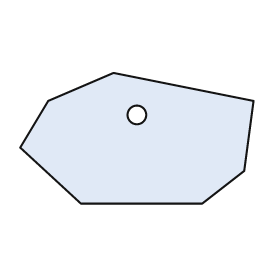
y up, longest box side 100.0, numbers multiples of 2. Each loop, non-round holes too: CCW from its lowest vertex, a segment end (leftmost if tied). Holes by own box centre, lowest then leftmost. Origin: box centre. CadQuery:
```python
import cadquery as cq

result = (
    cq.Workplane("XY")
    .moveTo(-24.0, -28.0)
    .lineTo(28.0, -28.0)
    .lineTo(46.0, -14.0)
    .lineTo(50.0, 16.0)
    .lineTo(-10.0, 28.0)
    .lineTo(-38.0, 16.0)
    .lineTo(-50.0, -4.0)
    .close()
    .moveTo(0.0, 10.0)
    .circle(4.0)
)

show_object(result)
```